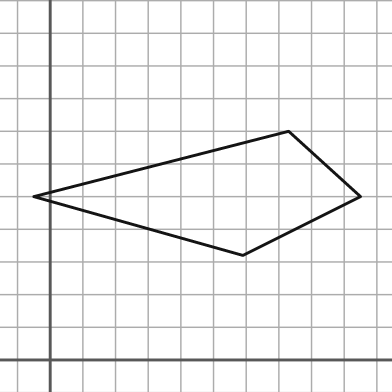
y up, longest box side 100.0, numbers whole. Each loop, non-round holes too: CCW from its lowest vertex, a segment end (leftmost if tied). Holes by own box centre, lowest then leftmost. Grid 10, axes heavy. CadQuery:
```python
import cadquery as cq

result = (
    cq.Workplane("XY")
    .moveTo(59.0, 32.0)
    .lineTo(95.0, 50.0)
    .lineTo(73.0, 70.0)
    .lineTo(-5.0, 50.0)
    .close()
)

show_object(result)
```